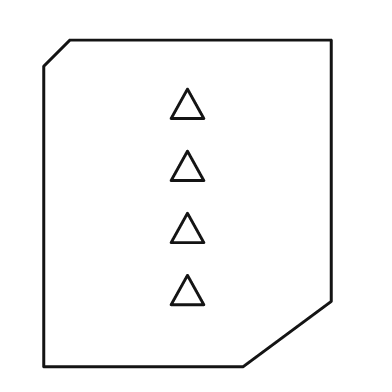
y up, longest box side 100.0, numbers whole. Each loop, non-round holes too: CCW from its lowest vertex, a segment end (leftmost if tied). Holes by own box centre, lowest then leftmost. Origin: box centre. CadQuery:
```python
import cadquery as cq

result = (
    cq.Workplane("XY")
    .moveTo(-44.0, -50.0)
    .lineTo(17.0, -50.0)
    .lineTo(44.0, -30.0)
    .lineTo(44.0, 50.0)
    .lineTo(-36.0, 50.0)
    .lineTo(-44.0, 42.0)
    .close()
    .moveTo(-5.0, -31.0)
    .lineTo(5.0, -31.0)
    .lineTo(0.0, -22.0)
    .close()
    .moveTo(-5.0, -12.0)
    .lineTo(5.0, -12.0)
    .lineTo(0.0, -3.0)
    .close()
    .moveTo(-5.0, 7.0)
    .lineTo(5.0, 7.0)
    .lineTo(0.0, 16.0)
    .close()
    .moveTo(-5.0, 26.0)
    .lineTo(5.0, 26.0)
    .lineTo(0.0, 35.0)
    .close()
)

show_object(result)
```